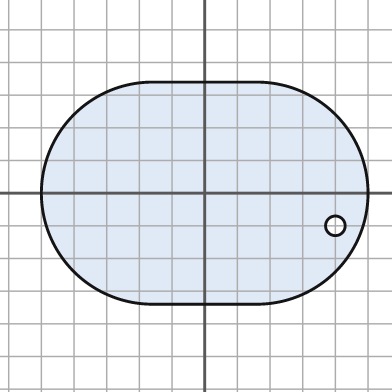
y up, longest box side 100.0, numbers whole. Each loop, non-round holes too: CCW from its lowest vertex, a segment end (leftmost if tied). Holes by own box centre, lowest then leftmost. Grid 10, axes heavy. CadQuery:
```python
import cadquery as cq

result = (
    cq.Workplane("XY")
    .moveTo(-16.0, -34.0)
    .lineTo(16.0, -34.0)
    .threePointArc((50.0, 0.0), (16.0, 34.0))
    .lineTo(-16.0, 34.0)
    .threePointArc((-50.0, 0.0), (-16.0, -34.0))
    .close()
    .moveTo(40.0, -10.0)
    .circle(3.0)
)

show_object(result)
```